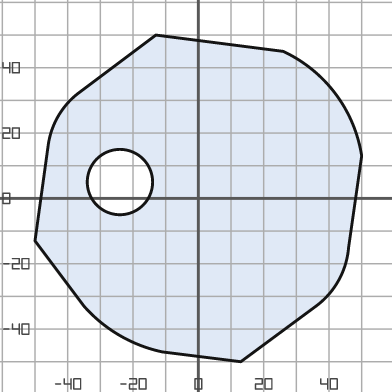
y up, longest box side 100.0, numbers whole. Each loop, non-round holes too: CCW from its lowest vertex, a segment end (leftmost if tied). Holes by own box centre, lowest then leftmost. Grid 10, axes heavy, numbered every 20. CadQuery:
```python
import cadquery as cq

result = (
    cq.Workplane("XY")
    .moveTo(13.0, -50.0)
    .lineTo(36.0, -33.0)
    .threePointArc((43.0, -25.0), (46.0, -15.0))
    .lineTo(50.0, 13.0)
    .threePointArc((42.0, 32.0), (26.0, 45.0))
    .lineTo(-13.0, 50.0)
    .lineTo(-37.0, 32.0)
    .threePointArc((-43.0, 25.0), (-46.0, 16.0))
    .lineTo(-50.0, -13.0)
    .lineTo(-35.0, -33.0)
    .threePointArc((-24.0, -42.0), (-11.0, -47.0))
    .close()
    .moveTo(-24.0, 5.0)
    .circle(10.0)
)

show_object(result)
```